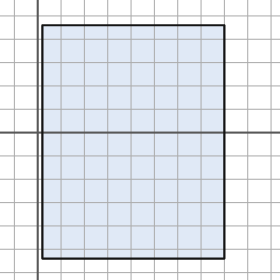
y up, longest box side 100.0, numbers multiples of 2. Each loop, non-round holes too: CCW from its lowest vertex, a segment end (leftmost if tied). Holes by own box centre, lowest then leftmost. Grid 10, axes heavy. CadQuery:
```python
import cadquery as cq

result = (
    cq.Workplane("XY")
    .moveTo(2.0, -54.0)
    .lineTo(80.0, -54.0)
    .lineTo(80.0, 46.0)
    .lineTo(2.0, 46.0)
    .close()
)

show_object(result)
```